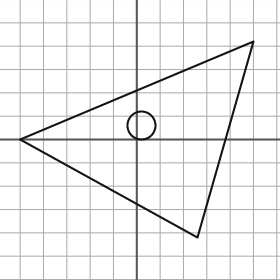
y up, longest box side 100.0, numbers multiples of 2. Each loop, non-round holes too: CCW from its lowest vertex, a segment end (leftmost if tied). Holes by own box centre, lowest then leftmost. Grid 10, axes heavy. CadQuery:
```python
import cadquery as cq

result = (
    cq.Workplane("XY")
    .moveTo(26.0, -42.0)
    .lineTo(50.0, 42.0)
    .lineTo(-50.0, 0.0)
    .close()
    .moveTo(2.0, 6.0)
    .circle(6.0)
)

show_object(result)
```